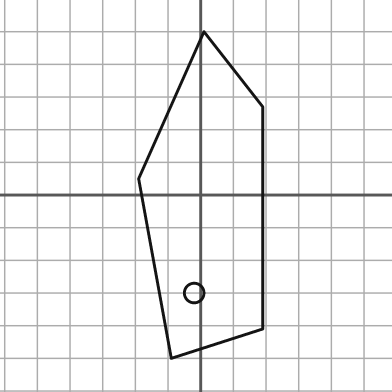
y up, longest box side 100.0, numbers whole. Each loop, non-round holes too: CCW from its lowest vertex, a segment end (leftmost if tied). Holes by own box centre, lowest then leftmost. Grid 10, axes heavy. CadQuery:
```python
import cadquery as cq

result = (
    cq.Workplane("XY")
    .moveTo(-9.0, -50.0)
    .lineTo(19.0, -41.0)
    .lineTo(19.0, 27.0)
    .lineTo(1.0, 50.0)
    .lineTo(-19.0, 5.0)
    .close()
    .moveTo(-2.0, -30.0)
    .circle(3.0)
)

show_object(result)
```